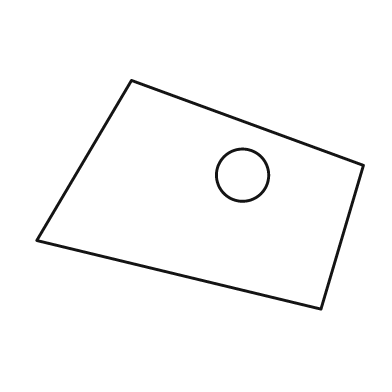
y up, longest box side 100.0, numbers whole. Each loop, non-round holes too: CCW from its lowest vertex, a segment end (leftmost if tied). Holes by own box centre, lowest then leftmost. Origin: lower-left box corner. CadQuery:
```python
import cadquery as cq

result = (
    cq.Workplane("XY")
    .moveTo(87.0, 0.0)
    .lineTo(100.0, 44.0)
    .lineTo(29.0, 70.0)
    .lineTo(0.0, 21.0)
    .close()
    .moveTo(63.0, 41.0)
    .circle(8.0)
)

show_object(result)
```